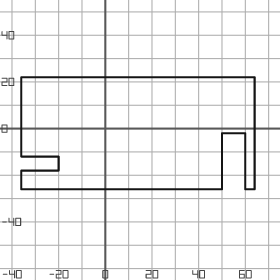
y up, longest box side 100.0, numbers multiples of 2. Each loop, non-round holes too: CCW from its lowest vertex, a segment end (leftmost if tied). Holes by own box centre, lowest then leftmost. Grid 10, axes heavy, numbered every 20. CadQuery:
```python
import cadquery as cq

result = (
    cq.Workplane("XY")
    .moveTo(-36.0, -26.0)
    .lineTo(50.0, -26.0)
    .lineTo(50.0, -2.0)
    .lineTo(60.0, -2.0)
    .lineTo(60.0, -26.0)
    .lineTo(64.0, -26.0)
    .lineTo(64.0, 22.0)
    .lineTo(-36.0, 22.0)
    .lineTo(-36.0, -12.0)
    .lineTo(-20.0, -12.0)
    .lineTo(-20.0, -18.0)
    .lineTo(-36.0, -18.0)
    .close()
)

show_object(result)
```